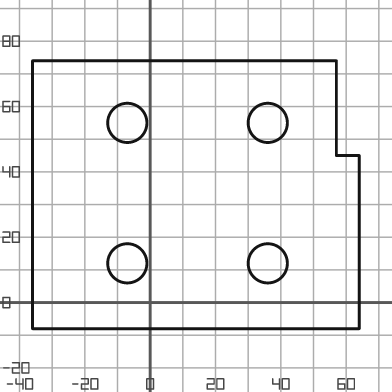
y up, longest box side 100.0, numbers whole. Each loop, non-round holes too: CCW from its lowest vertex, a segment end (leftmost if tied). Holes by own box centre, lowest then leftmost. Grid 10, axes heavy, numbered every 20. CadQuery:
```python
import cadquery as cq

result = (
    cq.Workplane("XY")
    .moveTo(-36.0, -8.0)
    .lineTo(64.0, -8.0)
    .lineTo(64.0, 45.0)
    .lineTo(57.0, 45.0)
    .lineTo(57.0, 74.0)
    .lineTo(-36.0, 74.0)
    .close()
    .moveTo(-7.0, 12.0)
    .circle(6.0)
    .moveTo(36.0, 12.0)
    .circle(6.0)
    .moveTo(-7.0, 55.0)
    .circle(6.0)
    .moveTo(36.0, 55.0)
    .circle(6.0)
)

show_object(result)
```